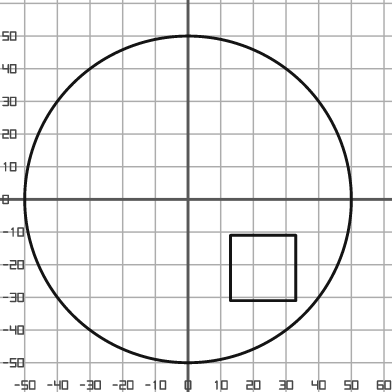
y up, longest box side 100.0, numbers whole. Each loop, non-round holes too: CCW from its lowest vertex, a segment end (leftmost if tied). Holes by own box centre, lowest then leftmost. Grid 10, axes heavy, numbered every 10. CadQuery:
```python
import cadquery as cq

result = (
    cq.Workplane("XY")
    .moveTo(0.0, 0.0)
    .circle(50.0)
    .moveTo(13.0, -31.0)
    .lineTo(33.0, -31.0)
    .lineTo(33.0, -11.0)
    .lineTo(13.0, -11.0)
    .close()
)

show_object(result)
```